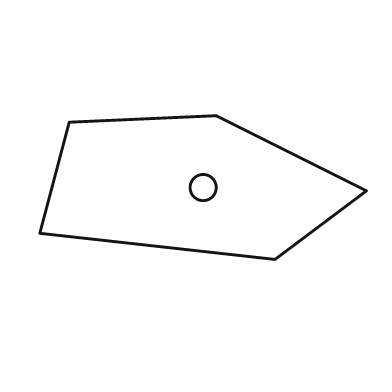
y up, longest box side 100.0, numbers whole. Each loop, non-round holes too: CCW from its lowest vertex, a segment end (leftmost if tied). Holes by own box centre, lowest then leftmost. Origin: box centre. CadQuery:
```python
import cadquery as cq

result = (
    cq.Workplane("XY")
    .moveTo(22.0, -22.0)
    .lineTo(50.0, -1.0)
    .lineTo(4.0, 22.0)
    .lineTo(-41.0, 20.0)
    .lineTo(-50.0, -14.0)
    .close()
    .moveTo(0.0, 0.0)
    .circle(4.0)
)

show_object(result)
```